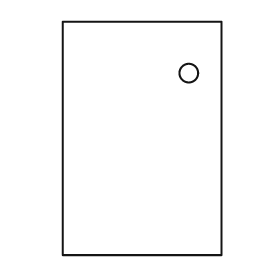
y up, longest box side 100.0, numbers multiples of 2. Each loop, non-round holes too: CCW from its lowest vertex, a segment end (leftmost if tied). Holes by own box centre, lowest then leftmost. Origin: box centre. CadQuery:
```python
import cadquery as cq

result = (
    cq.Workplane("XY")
    .moveTo(-34.0, -50.0)
    .lineTo(34.0, -50.0)
    .lineTo(34.0, 50.0)
    .lineTo(-34.0, 50.0)
    .close()
    .moveTo(20.0, 28.0)
    .circle(4.0)
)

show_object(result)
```